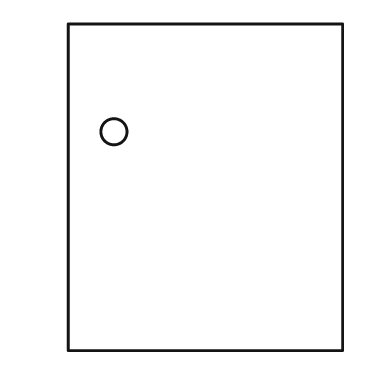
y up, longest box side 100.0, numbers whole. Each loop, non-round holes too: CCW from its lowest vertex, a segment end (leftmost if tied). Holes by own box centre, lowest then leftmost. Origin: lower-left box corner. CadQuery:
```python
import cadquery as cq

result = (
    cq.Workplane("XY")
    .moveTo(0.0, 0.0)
    .lineTo(84.0, 0.0)
    .lineTo(84.0, 100.0)
    .lineTo(0.0, 100.0)
    .close()
    .moveTo(14.0, 67.0)
    .circle(4.0)
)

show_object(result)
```